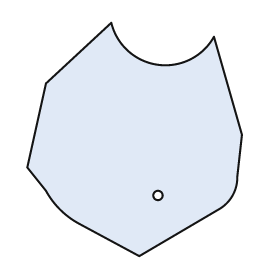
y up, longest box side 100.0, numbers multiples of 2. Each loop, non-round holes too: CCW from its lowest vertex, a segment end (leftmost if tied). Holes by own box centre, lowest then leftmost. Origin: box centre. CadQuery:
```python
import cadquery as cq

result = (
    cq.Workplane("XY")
    .moveTo(2.0, -50.0)
    .lineTo(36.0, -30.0)
    .threePointArc((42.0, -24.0), (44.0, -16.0))
    .lineTo(46.0, 2.0)
    .lineTo(34.0, 44.0)
    .threePointArc((10.0, 32.0), (-10.0, 50.0))
    .lineTo(-38.0, 24.0)
    .lineTo(-46.0, -12.0)
    .lineTo(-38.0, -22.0)
    .threePointArc((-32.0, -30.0), (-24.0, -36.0))
    .close()
    .moveTo(10.0, -24.0)
    .circle(2.0)
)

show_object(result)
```